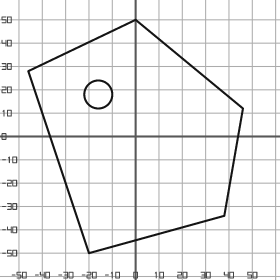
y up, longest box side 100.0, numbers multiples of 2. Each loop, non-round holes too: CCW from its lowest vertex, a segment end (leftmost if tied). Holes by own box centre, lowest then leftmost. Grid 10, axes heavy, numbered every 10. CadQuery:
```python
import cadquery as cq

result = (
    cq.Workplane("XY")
    .moveTo(-20.0, -50.0)
    .lineTo(38.0, -34.0)
    .lineTo(46.0, 12.0)
    .lineTo(0.0, 50.0)
    .lineTo(-46.0, 28.0)
    .close()
    .moveTo(-16.0, 18.0)
    .circle(6.0)
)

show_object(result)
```